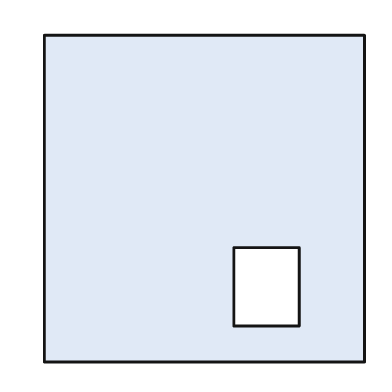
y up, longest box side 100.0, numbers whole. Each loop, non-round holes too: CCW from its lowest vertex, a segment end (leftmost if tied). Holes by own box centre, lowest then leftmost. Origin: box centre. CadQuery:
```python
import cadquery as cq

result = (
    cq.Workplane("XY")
    .moveTo(-49.0, -50.0)
    .lineTo(49.0, -50.0)
    .lineTo(49.0, 50.0)
    .lineTo(-49.0, 50.0)
    .close()
    .moveTo(9.0, -39.0)
    .lineTo(29.0, -39.0)
    .lineTo(29.0, -15.0)
    .lineTo(9.0, -15.0)
    .close()
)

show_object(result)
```